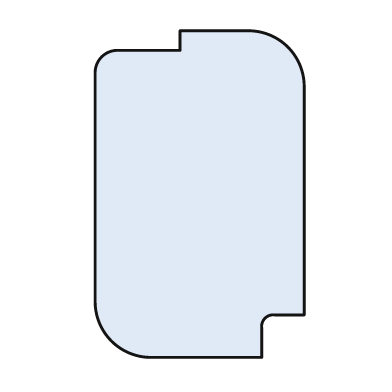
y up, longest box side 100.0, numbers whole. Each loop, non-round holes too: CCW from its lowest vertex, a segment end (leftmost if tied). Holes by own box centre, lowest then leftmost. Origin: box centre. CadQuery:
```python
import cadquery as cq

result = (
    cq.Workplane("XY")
    .moveTo(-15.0, -50.0)
    .lineTo(19.0, -50.0)
    .lineTo(19.0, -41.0)
    .threePointArc((20.0, -38.0), (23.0, -37.0))
    .lineTo(32.0, -37.0)
    .lineTo(32.0, 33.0)
    .threePointArc((27.0, 45.0), (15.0, 50.0))
    .lineTo(-6.0, 50.0)
    .lineTo(-6.0, 44.0)
    .lineTo(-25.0, 44.0)
    .threePointArc((-30.0, 42.0), (-32.0, 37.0))
    .lineTo(-32.0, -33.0)
    .threePointArc((-27.0, -45.0), (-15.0, -50.0))
    .close()
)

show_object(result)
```